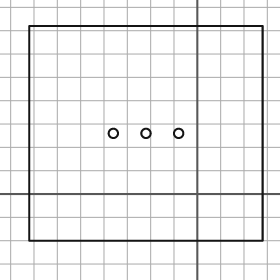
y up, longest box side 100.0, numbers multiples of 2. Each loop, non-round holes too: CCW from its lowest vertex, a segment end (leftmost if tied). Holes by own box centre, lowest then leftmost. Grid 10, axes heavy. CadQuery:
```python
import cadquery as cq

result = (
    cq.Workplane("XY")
    .moveTo(-72.0, -20.0)
    .lineTo(28.0, -20.0)
    .lineTo(28.0, 72.0)
    .lineTo(-72.0, 72.0)
    .close()
    .moveTo(-36.0, 26.0)
    .circle(2.0)
    .moveTo(-22.0, 26.0)
    .circle(2.0)
    .moveTo(-8.0, 26.0)
    .circle(2.0)
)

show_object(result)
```